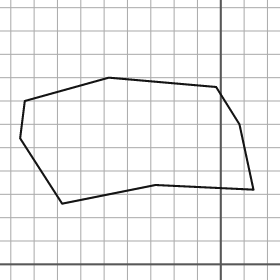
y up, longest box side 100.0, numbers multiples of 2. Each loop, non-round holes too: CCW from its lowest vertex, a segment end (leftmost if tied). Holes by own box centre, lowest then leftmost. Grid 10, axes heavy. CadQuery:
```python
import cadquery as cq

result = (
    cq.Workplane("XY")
    .moveTo(-68.0, 26.0)
    .lineTo(-28.0, 34.0)
    .lineTo(14.0, 32.0)
    .lineTo(8.0, 60.0)
    .lineTo(-2.0, 76.0)
    .lineTo(-48.0, 80.0)
    .lineTo(-84.0, 70.0)
    .lineTo(-86.0, 54.0)
    .close()
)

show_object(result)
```